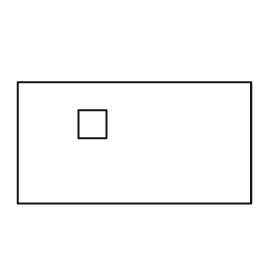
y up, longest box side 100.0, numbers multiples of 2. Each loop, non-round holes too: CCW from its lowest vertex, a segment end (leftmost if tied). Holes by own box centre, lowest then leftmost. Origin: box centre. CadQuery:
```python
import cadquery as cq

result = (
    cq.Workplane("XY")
    .moveTo(-50.0, -26.0)
    .lineTo(50.0, -26.0)
    .lineTo(50.0, 26.0)
    .lineTo(-50.0, 26.0)
    .close()
    .moveTo(-24.0, 2.0)
    .lineTo(-12.0, 2.0)
    .lineTo(-12.0, 14.0)
    .lineTo(-24.0, 14.0)
    .close()
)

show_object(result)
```